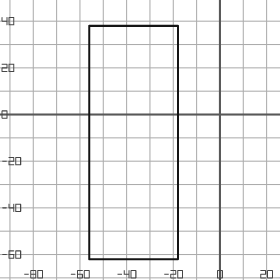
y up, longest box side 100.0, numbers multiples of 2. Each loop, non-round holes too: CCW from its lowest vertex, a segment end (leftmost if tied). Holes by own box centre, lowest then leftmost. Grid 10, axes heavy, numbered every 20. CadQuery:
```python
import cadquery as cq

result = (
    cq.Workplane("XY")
    .moveTo(-56.0, -62.0)
    .lineTo(-18.0, -62.0)
    .lineTo(-18.0, 38.0)
    .lineTo(-56.0, 38.0)
    .close()
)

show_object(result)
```